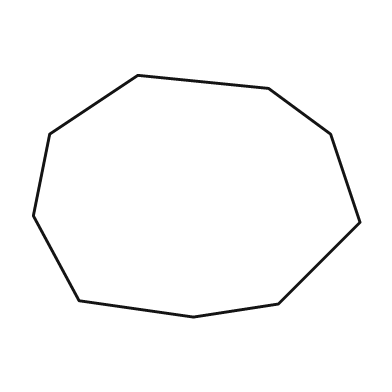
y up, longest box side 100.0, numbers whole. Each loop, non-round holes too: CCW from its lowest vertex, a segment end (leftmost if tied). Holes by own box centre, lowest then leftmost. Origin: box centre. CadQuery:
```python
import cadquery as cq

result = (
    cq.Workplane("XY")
    .moveTo(-1.0, -37.0)
    .lineTo(25.0, -33.0)
    .lineTo(50.0, -8.0)
    .lineTo(41.0, 19.0)
    .lineTo(22.0, 33.0)
    .lineTo(-18.0, 37.0)
    .lineTo(-45.0, 19.0)
    .lineTo(-50.0, -6.0)
    .lineTo(-36.0, -32.0)
    .close()
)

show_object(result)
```